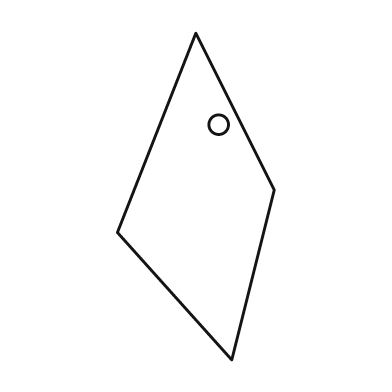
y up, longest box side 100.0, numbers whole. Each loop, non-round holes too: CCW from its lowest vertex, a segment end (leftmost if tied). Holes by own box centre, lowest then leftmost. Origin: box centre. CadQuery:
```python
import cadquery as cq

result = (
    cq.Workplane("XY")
    .moveTo(11.0, -50.0)
    .lineTo(24.0, 2.0)
    .lineTo(0.0, 50.0)
    .lineTo(-24.0, -11.0)
    .close()
    .moveTo(7.0, 22.0)
    .circle(3.0)
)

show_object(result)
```